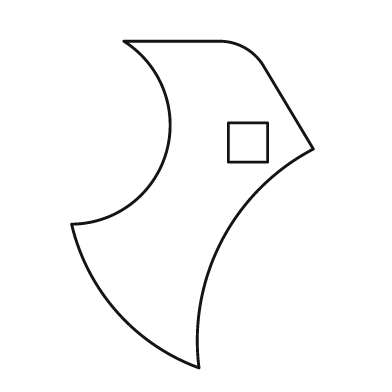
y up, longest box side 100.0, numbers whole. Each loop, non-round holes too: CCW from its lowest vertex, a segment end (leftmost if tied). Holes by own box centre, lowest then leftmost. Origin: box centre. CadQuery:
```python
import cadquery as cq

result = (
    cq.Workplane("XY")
    .moveTo(2.0, -50.0)
    .threePointArc((9.0, -11.0), (37.0, 17.0))
    .lineTo(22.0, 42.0)
    .threePointArc((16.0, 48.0), (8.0, 50.0))
    .lineTo(-21.0, 50.0)
    .threePointArc((-8.0, 16.0), (-37.0, -6.0))
    .threePointArc((-23.0, -33.0), (2.0, -50.0))
    .close()
    .moveTo(11.0, 13.0)
    .lineTo(23.0, 13.0)
    .lineTo(23.0, 25.0)
    .lineTo(11.0, 25.0)
    .close()
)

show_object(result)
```